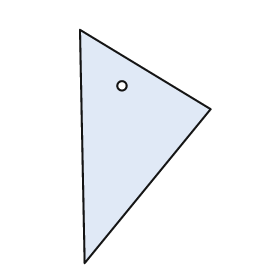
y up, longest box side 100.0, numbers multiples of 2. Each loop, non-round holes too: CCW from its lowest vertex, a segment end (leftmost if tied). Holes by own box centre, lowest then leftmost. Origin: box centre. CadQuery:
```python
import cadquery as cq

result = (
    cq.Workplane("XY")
    .moveTo(-26.0, -50.0)
    .lineTo(28.0, 16.0)
    .lineTo(-28.0, 50.0)
    .close()
    .moveTo(-10.0, 26.0)
    .circle(2.0)
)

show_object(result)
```